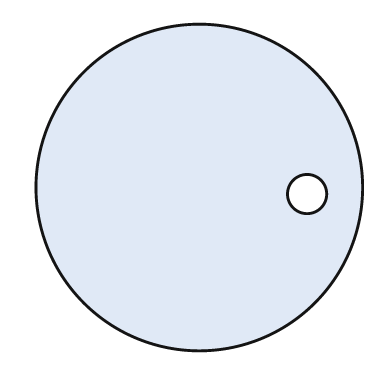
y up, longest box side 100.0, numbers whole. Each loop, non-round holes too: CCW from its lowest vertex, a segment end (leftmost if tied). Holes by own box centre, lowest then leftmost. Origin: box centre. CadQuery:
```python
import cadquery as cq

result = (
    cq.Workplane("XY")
    .moveTo(0.0, 0.0)
    .circle(50.0)
    .moveTo(33.0, -2.0)
    .circle(6.0)
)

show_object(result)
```